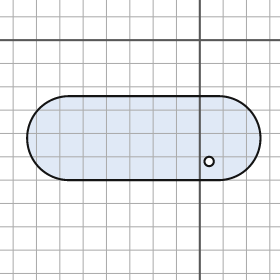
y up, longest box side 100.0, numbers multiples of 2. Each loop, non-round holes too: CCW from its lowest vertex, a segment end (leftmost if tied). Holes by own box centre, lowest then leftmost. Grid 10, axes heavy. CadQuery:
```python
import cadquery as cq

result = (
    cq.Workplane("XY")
    .moveTo(-56.0, -60.0)
    .lineTo(8.0, -60.0)
    .threePointArc((26.0, -42.0), (8.0, -24.0))
    .lineTo(-56.0, -24.0)
    .threePointArc((-74.0, -42.0), (-56.0, -60.0))
    .close()
    .moveTo(4.0, -52.0)
    .circle(2.0)
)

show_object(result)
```